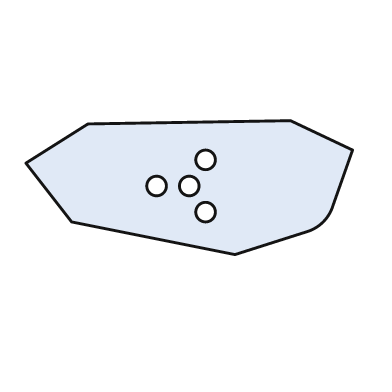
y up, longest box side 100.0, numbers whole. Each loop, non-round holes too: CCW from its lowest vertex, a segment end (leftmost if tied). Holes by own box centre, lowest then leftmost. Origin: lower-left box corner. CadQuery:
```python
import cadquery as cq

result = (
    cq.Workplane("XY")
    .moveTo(64.0, 0.0)
    .lineTo(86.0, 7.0)
    .threePointArc((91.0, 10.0), (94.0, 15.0))
    .lineTo(100.0, 32.0)
    .lineTo(81.0, 41.0)
    .lineTo(19.0, 40.0)
    .lineTo(0.0, 28.0)
    .lineTo(14.0, 10.0)
    .close()
    .moveTo(55.0, 13.0)
    .circle(3.0)
    .moveTo(40.0, 21.0)
    .circle(3.0)
    .moveTo(50.0, 21.0)
    .circle(3.0)
    .moveTo(55.0, 29.0)
    .circle(3.0)
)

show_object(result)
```